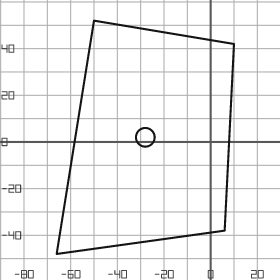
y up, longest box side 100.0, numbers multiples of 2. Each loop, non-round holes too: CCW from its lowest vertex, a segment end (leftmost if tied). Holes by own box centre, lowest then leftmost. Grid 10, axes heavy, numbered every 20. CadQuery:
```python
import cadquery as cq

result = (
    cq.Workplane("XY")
    .moveTo(-66.0, -48.0)
    .lineTo(6.0, -38.0)
    .lineTo(10.0, 42.0)
    .lineTo(-50.0, 52.0)
    .close()
    .moveTo(-28.0, 2.0)
    .circle(4.0)
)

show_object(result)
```